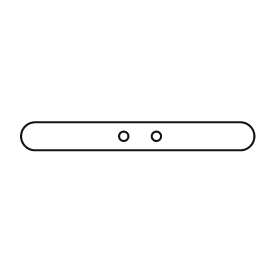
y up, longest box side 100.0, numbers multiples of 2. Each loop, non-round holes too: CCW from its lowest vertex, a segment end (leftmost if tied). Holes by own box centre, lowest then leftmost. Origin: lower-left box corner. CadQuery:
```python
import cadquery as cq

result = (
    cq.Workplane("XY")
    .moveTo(6.0, 0.0)
    .lineTo(94.0, 0.0)
    .threePointArc((100.0, 6.0), (94.0, 12.0))
    .lineTo(6.0, 12.0)
    .threePointArc((0.0, 6.0), (6.0, 0.0))
    .close()
    .moveTo(44.0, 6.0)
    .circle(2.0)
    .moveTo(58.0, 6.0)
    .circle(2.0)
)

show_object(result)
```